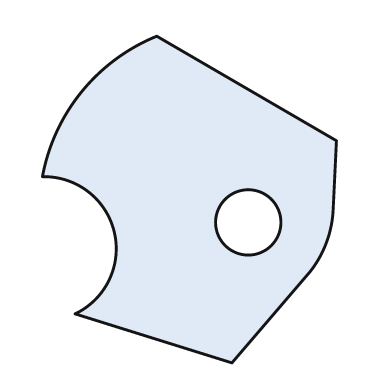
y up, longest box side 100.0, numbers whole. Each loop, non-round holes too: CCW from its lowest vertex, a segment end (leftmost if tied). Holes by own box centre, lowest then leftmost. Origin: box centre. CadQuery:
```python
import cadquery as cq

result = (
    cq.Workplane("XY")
    .moveTo(13.0, -50.0)
    .lineTo(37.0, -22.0)
    .threePointArc((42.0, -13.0), (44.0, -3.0))
    .lineTo(45.0, 18.0)
    .lineTo(-10.0, 50.0)
    .threePointArc((-33.0, 33.0), (-45.0, 7.0))
    .threePointArc((-23.0, -10.0), (-35.0, -35.0))
    .close()
    .moveTo(18.0, -7.0)
    .circle(10.0)
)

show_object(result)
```